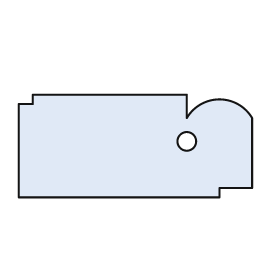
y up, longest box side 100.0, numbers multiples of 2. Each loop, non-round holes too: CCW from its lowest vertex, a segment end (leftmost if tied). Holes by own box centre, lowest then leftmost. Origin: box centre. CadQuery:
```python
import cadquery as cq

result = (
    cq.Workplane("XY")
    .moveTo(-50.0, -22.0)
    .lineTo(36.0, -22.0)
    .lineTo(36.0, -18.0)
    .lineTo(50.0, -18.0)
    .lineTo(50.0, 12.0)
    .threePointArc((36.0, 20.0), (22.0, 12.0))
    .lineTo(22.0, 22.0)
    .lineTo(-44.0, 22.0)
    .lineTo(-44.0, 18.0)
    .lineTo(-50.0, 18.0)
    .close()
    .moveTo(22.0, 2.0)
    .circle(4.0)
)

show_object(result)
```